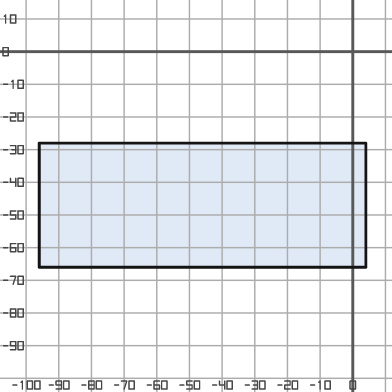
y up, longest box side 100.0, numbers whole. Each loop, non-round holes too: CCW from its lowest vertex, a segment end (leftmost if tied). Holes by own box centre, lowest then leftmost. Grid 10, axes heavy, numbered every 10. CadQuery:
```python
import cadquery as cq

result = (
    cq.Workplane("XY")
    .moveTo(-96.0, -66.0)
    .lineTo(4.0, -66.0)
    .lineTo(4.0, -28.0)
    .lineTo(-96.0, -28.0)
    .close()
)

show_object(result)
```